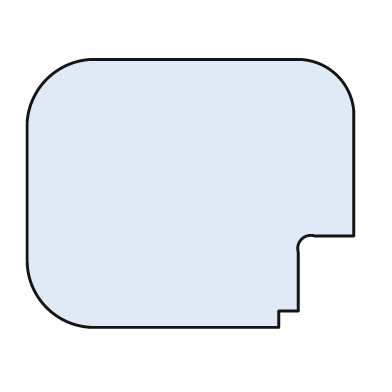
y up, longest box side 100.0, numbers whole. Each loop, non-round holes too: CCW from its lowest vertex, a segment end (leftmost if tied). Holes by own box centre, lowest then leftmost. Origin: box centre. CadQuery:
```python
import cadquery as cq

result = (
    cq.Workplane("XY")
    .moveTo(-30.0, -41.0)
    .lineTo(27.0, -41.0)
    .lineTo(27.0, -36.0)
    .lineTo(33.0, -36.0)
    .lineTo(33.0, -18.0)
    .threePointArc((34.0, -14.0), (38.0, -13.0))
    .lineTo(50.0, -13.0)
    .lineTo(50.0, 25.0)
    .threePointArc((45.0, 36.0), (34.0, 41.0))
    .lineTo(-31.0, 41.0)
    .threePointArc((-44.0, 35.0), (-50.0, 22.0))
    .lineTo(-50.0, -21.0)
    .threePointArc((-44.0, -35.0), (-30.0, -41.0))
    .close()
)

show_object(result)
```